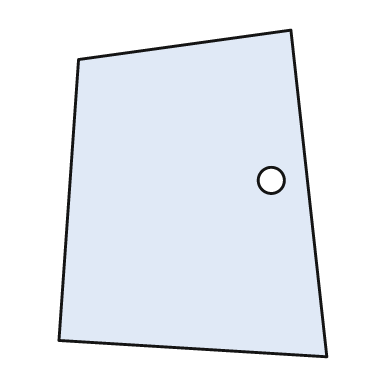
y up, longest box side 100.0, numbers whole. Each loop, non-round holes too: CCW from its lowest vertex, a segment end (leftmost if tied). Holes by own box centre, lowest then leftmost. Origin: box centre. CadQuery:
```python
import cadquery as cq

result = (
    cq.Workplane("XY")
    .moveTo(41.0, -50.0)
    .lineTo(30.0, 50.0)
    .lineTo(-35.0, 41.0)
    .lineTo(-41.0, -45.0)
    .close()
    .moveTo(24.0, 4.0)
    .circle(4.0)
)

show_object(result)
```